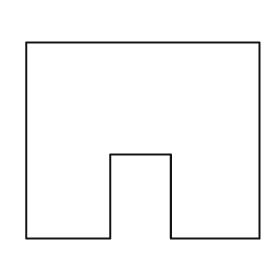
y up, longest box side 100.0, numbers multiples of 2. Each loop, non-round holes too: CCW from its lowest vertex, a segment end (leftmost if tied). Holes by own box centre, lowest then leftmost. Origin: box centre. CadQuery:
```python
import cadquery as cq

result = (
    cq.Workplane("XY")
    .moveTo(-50.0, -42.0)
    .lineTo(-14.0, -42.0)
    .lineTo(-14.0, -6.0)
    .lineTo(12.0, -6.0)
    .lineTo(12.0, -42.0)
    .lineTo(50.0, -42.0)
    .lineTo(50.0, 42.0)
    .lineTo(-50.0, 42.0)
    .close()
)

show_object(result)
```